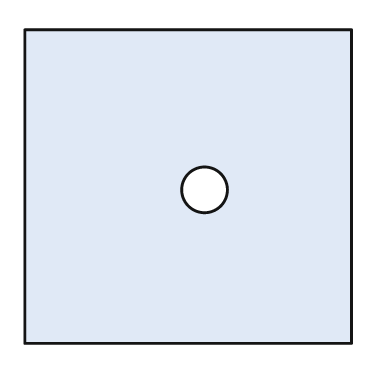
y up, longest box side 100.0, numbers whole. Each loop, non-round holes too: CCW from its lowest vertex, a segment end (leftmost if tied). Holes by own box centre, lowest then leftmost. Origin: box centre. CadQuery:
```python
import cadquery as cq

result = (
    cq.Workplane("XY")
    .moveTo(-50.0, -48.0)
    .lineTo(50.0, -48.0)
    .lineTo(50.0, 48.0)
    .lineTo(-50.0, 48.0)
    .close()
    .moveTo(5.0, -1.0)
    .circle(7.0)
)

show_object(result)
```